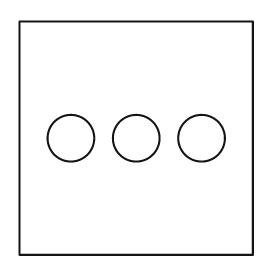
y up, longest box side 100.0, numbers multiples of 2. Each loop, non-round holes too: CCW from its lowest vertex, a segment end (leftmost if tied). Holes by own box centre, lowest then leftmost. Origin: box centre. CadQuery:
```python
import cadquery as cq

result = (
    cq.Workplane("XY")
    .moveTo(-50.0, -50.0)
    .lineTo(50.0, -50.0)
    .lineTo(50.0, 50.0)
    .lineTo(-50.0, 50.0)
    .close()
    .moveTo(-28.0, 0.0)
    .circle(10.0)
    .moveTo(0.0, 0.0)
    .circle(10.0)
    .moveTo(28.0, 0.0)
    .circle(10.0)
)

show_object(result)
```